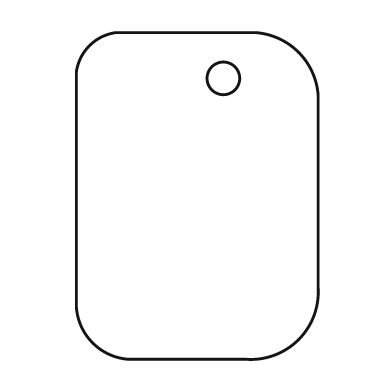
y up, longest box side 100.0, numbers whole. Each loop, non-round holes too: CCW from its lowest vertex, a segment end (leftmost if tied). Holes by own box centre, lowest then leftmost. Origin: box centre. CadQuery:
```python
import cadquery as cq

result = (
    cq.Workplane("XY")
    .moveTo(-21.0, -50.0)
    .lineTo(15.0, -50.0)
    .threePointArc((31.0, -44.0), (37.0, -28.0))
    .lineTo(37.0, 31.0)
    .threePointArc((31.0, 44.0), (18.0, 50.0))
    .lineTo(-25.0, 50.0)
    .threePointArc((-33.0, 46.0), (-37.0, 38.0))
    .lineTo(-37.0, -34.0)
    .threePointArc((-32.0, -45.0), (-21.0, -50.0))
    .close()
    .moveTo(8.0, 36.0)
    .circle(5.0)
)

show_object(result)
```